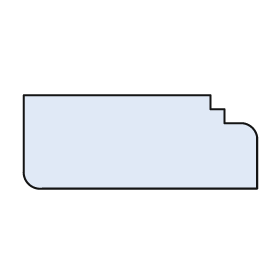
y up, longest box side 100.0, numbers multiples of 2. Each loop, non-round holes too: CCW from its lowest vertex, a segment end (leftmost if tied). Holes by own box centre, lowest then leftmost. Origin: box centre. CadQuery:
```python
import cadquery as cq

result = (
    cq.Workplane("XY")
    .moveTo(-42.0, -20.0)
    .lineTo(50.0, -20.0)
    .lineTo(50.0, 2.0)
    .threePointArc((48.0, 6.0), (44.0, 8.0))
    .lineTo(36.0, 8.0)
    .lineTo(36.0, 14.0)
    .lineTo(30.0, 14.0)
    .lineTo(30.0, 20.0)
    .lineTo(-50.0, 20.0)
    .lineTo(-50.0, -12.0)
    .threePointArc((-48.0, -18.0), (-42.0, -20.0))
    .close()
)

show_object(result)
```